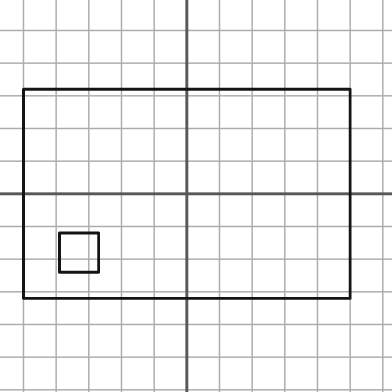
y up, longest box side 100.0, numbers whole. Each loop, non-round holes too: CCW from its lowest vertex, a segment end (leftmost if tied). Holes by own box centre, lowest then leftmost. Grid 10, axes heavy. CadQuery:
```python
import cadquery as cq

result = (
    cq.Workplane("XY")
    .moveTo(-50.0, -32.0)
    .lineTo(50.0, -32.0)
    .lineTo(50.0, 32.0)
    .lineTo(-50.0, 32.0)
    .close()
    .moveTo(-39.0, -24.0)
    .lineTo(-27.0, -24.0)
    .lineTo(-27.0, -12.0)
    .lineTo(-39.0, -12.0)
    .close()
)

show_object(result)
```